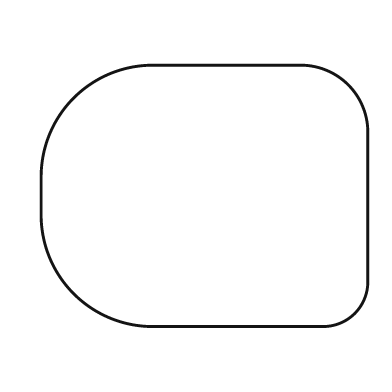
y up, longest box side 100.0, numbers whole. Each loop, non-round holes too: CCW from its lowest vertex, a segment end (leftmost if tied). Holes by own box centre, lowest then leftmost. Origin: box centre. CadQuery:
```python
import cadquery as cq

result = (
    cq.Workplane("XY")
    .moveTo(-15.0, -40.0)
    .lineTo(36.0, -40.0)
    .threePointArc((46.0, -36.0), (50.0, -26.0))
    .lineTo(50.0, 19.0)
    .threePointArc((44.0, 34.0), (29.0, 40.0))
    .lineTo(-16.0, 40.0)
    .threePointArc((-40.0, 30.0), (-50.0, 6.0))
    .lineTo(-50.0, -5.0)
    .threePointArc((-40.0, -30.0), (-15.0, -40.0))
    .close()
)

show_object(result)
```